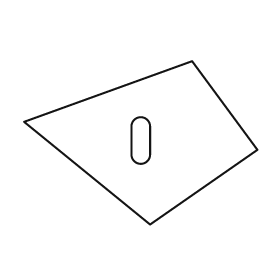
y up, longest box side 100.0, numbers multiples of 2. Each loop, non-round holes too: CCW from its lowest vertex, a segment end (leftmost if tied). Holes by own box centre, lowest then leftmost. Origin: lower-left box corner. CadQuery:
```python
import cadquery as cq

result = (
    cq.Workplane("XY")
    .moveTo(54.0, 0.0)
    .lineTo(100.0, 32.0)
    .lineTo(72.0, 70.0)
    .lineTo(0.0, 44.0)
    .close()
    .moveTo(46.0, 30.0)
    .threePointArc((50.0, 26.0), (54.0, 30.0))
    .lineTo(54.0, 42.0)
    .threePointArc((50.0, 46.0), (46.0, 42.0))
    .close()
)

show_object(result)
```